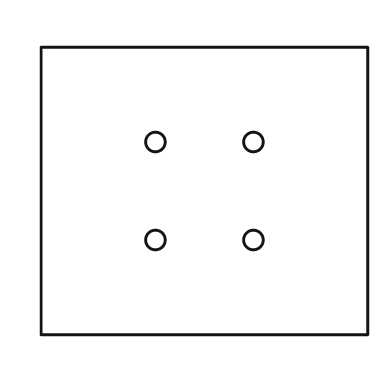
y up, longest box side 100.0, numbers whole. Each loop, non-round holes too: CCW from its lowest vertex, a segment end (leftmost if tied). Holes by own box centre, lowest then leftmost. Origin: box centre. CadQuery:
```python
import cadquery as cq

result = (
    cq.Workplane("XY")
    .moveTo(-50.0, -44.0)
    .lineTo(50.0, -44.0)
    .lineTo(50.0, 44.0)
    .lineTo(-50.0, 44.0)
    .close()
    .moveTo(-15.0, -15.0)
    .circle(3.0)
    .moveTo(15.0, -15.0)
    .circle(3.0)
    .moveTo(-15.0, 15.0)
    .circle(3.0)
    .moveTo(15.0, 15.0)
    .circle(3.0)
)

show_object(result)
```